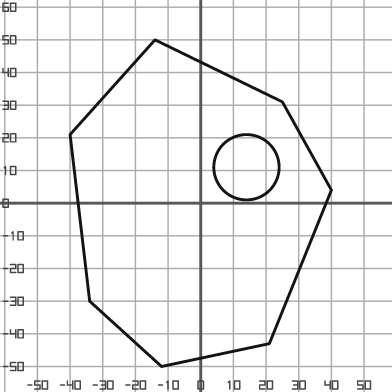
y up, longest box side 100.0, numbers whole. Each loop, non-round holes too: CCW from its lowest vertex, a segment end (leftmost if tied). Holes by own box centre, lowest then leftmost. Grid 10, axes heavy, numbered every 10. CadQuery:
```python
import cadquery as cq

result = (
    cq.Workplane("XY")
    .moveTo(-12.0, -50.0)
    .lineTo(21.0, -43.0)
    .lineTo(40.0, 4.0)
    .lineTo(25.0, 31.0)
    .lineTo(-14.0, 50.0)
    .lineTo(-40.0, 21.0)
    .lineTo(-34.0, -30.0)
    .close()
    .moveTo(14.0, 11.0)
    .circle(10.0)
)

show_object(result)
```